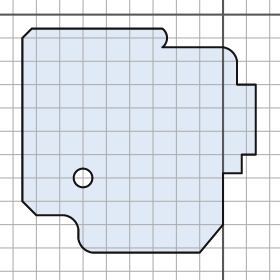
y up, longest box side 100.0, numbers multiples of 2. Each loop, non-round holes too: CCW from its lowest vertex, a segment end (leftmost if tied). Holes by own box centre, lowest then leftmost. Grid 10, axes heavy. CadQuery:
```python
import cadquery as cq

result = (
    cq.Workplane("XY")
    .moveTo(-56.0, -102.0)
    .lineTo(-10.0, -102.0)
    .lineTo(0.0, -90.0)
    .lineTo(0.0, -68.0)
    .lineTo(8.0, -68.0)
    .lineTo(8.0, -60.0)
    .lineTo(14.0, -60.0)
    .lineTo(14.0, -30.0)
    .lineTo(6.0, -30.0)
    .lineTo(6.0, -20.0)
    .threePointArc((4.0, -16.0), (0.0, -14.0))
    .lineTo(-26.0, -14.0)
    .threePointArc((-24.0, -10.0), (-26.0, -6.0))
    .lineTo(-82.0, -6.0)
    .lineTo(-86.0, -10.0)
    .lineTo(-86.0, -80.0)
    .lineTo(-80.0, -86.0)
    .lineTo(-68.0, -86.0)
    .threePointArc((-64.0, -88.0), (-62.0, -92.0))
    .lineTo(-62.0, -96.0)
    .threePointArc((-60.0, -100.0), (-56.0, -102.0))
    .close()
    .moveTo(-60.0, -70.0)
    .circle(4.0)
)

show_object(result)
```